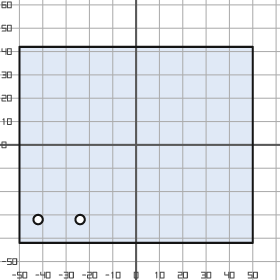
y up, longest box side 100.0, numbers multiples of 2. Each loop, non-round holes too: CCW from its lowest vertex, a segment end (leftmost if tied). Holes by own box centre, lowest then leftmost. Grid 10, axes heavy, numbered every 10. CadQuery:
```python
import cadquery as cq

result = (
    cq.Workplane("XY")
    .moveTo(-50.0, -42.0)
    .lineTo(50.0, -42.0)
    .lineTo(50.0, 42.0)
    .lineTo(-50.0, 42.0)
    .close()
    .moveTo(-42.0, -32.0)
    .circle(2.0)
    .moveTo(-24.0, -32.0)
    .circle(2.0)
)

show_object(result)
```